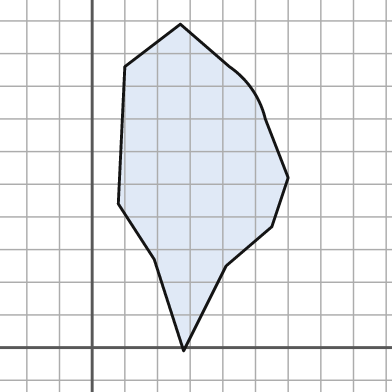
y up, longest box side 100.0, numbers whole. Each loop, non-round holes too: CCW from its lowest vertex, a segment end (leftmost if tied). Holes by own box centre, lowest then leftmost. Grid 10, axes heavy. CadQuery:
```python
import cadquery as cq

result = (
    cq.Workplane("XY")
    .moveTo(28.0, -1.0)
    .lineTo(41.0, 25.0)
    .lineTo(55.0, 37.0)
    .lineTo(60.0, 52.0)
    .lineTo(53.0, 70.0)
    .threePointArc((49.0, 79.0), (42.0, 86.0))
    .lineTo(27.0, 99.0)
    .lineTo(10.0, 86.0)
    .lineTo(8.0, 44.0)
    .lineTo(19.0, 27.0)
    .close()
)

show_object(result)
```